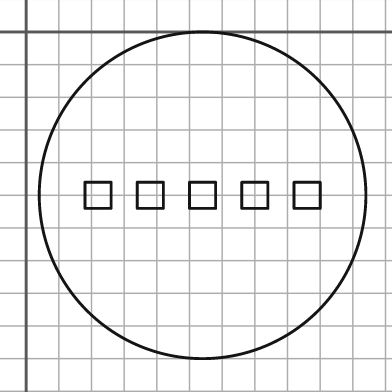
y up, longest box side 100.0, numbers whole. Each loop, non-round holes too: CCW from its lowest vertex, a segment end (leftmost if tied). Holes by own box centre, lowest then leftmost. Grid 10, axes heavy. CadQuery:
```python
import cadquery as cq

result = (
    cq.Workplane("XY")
    .moveTo(54.0, -50.0)
    .circle(50.0)
    .moveTo(18.0, -54.0)
    .lineTo(26.0, -54.0)
    .lineTo(26.0, -46.0)
    .lineTo(18.0, -46.0)
    .close()
    .moveTo(34.0, -54.0)
    .lineTo(42.0, -54.0)
    .lineTo(42.0, -46.0)
    .lineTo(34.0, -46.0)
    .close()
    .moveTo(50.0, -54.0)
    .lineTo(58.0, -54.0)
    .lineTo(58.0, -46.0)
    .lineTo(50.0, -46.0)
    .close()
    .moveTo(66.0, -54.0)
    .lineTo(74.0, -54.0)
    .lineTo(74.0, -46.0)
    .lineTo(66.0, -46.0)
    .close()
    .moveTo(82.0, -54.0)
    .lineTo(90.0, -54.0)
    .lineTo(90.0, -46.0)
    .lineTo(82.0, -46.0)
    .close()
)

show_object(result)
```